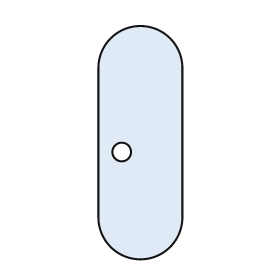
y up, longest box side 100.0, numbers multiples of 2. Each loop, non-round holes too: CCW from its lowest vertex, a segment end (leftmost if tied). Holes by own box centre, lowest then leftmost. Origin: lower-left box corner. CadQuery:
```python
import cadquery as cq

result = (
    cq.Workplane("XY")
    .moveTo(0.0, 18.0)
    .threePointArc((18.0, 0.0), (36.0, 18.0))
    .lineTo(36.0, 82.0)
    .threePointArc((18.0, 100.0), (0.0, 82.0))
    .close()
    .moveTo(10.0, 46.0)
    .circle(4.0)
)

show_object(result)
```